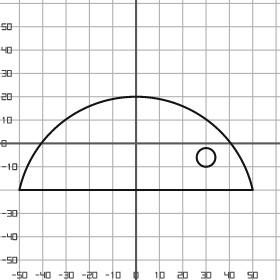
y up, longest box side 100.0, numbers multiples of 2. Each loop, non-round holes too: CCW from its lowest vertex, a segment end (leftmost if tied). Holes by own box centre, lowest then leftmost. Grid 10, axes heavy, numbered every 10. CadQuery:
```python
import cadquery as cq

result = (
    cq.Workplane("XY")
    .moveTo(-50.0, -20.0)
    .lineTo(50.0, -20.0)
    .threePointArc((0.0, 20.0), (-50.0, -20.0))
    .close()
    .moveTo(30.0, -6.0)
    .circle(4.0)
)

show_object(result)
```